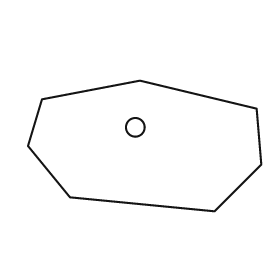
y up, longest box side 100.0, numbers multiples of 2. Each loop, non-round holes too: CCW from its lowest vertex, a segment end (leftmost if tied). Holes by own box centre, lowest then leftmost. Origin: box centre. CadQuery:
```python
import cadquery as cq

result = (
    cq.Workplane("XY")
    .moveTo(30.0, -28.0)
    .lineTo(50.0, -8.0)
    .lineTo(48.0, 16.0)
    .lineTo(-2.0, 28.0)
    .lineTo(-44.0, 20.0)
    .lineTo(-50.0, 0.0)
    .lineTo(-32.0, -22.0)
    .close()
    .moveTo(-4.0, 8.0)
    .circle(4.0)
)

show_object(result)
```